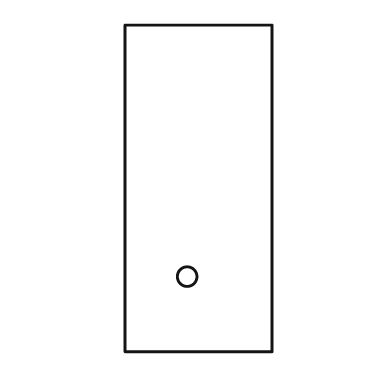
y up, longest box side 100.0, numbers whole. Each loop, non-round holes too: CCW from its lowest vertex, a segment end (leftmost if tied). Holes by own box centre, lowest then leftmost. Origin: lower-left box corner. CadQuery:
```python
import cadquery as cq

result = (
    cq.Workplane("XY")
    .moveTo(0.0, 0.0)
    .lineTo(45.0, 0.0)
    .lineTo(45.0, 100.0)
    .lineTo(0.0, 100.0)
    .close()
    .moveTo(19.0, 23.0)
    .circle(3.0)
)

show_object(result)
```